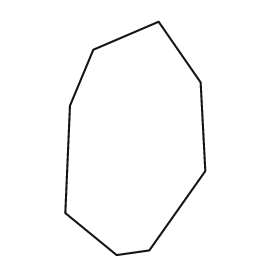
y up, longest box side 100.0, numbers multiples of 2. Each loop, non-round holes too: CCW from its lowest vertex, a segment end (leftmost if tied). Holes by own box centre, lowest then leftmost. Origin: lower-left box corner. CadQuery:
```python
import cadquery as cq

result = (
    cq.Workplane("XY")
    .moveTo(22.0, 0.0)
    .lineTo(36.0, 2.0)
    .lineTo(60.0, 36.0)
    .lineTo(58.0, 74.0)
    .lineTo(40.0, 100.0)
    .lineTo(12.0, 88.0)
    .lineTo(2.0, 64.0)
    .lineTo(0.0, 18.0)
    .close()
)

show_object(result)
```